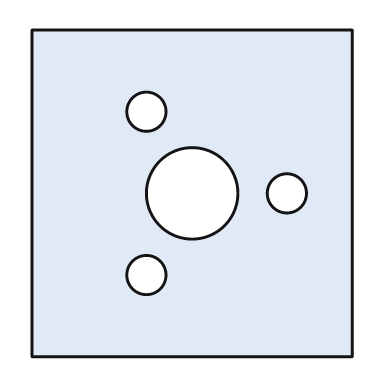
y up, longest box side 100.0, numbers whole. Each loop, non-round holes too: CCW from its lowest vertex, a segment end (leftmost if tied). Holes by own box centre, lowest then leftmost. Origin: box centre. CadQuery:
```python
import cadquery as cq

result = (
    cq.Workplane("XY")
    .moveTo(-49.0, -50.0)
    .lineTo(49.0, -50.0)
    .lineTo(49.0, 50.0)
    .lineTo(-49.0, 50.0)
    .close()
    .moveTo(-14.0, -25.0)
    .circle(6.0)
    .moveTo(0.0, 0.0)
    .circle(14.0)
    .moveTo(29.0, 0.0)
    .circle(6.0)
    .moveTo(-14.0, 25.0)
    .circle(6.0)
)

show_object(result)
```